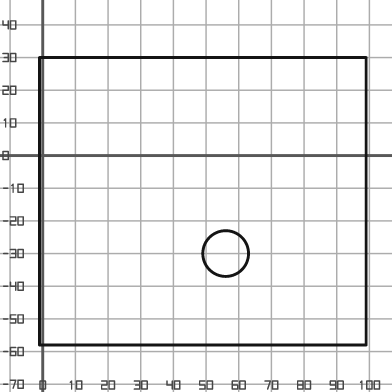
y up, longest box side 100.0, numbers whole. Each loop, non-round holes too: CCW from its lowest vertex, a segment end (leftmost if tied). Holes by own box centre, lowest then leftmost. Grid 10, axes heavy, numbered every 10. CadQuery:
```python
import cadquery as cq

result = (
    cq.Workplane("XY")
    .moveTo(-1.0, -58.0)
    .lineTo(99.0, -58.0)
    .lineTo(99.0, 30.0)
    .lineTo(-1.0, 30.0)
    .close()
    .moveTo(56.0, -30.0)
    .circle(7.0)
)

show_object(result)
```